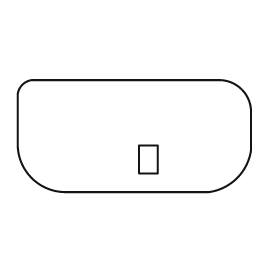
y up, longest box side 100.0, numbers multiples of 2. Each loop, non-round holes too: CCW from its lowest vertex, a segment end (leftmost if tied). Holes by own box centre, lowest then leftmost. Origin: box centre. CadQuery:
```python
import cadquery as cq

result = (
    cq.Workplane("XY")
    .moveTo(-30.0, -24.0)
    .lineTo(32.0, -24.0)
    .threePointArc((44.0, -18.0), (50.0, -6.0))
    .lineTo(50.0, 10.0)
    .threePointArc((46.0, 20.0), (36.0, 24.0))
    .lineTo(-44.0, 24.0)
    .threePointArc((-48.0, 22.0), (-50.0, 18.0))
    .lineTo(-50.0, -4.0)
    .threePointArc((-44.0, -18.0), (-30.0, -24.0))
    .close()
    .moveTo(2.0, -16.0)
    .lineTo(10.0, -16.0)
    .lineTo(10.0, -4.0)
    .lineTo(2.0, -4.0)
    .close()
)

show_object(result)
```